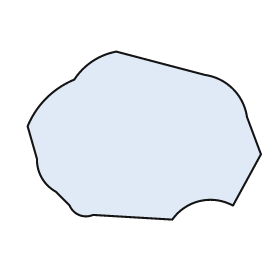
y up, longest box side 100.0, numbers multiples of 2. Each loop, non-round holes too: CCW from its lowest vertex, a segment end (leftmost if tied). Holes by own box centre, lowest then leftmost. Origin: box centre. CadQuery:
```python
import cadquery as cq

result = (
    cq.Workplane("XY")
    .moveTo(12.0, -36.0)
    .threePointArc((24.0, -28.0), (38.0, -30.0))
    .lineTo(50.0, -8.0)
    .lineTo(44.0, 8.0)
    .threePointArc((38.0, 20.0), (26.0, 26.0))
    .lineTo(-12.0, 36.0)
    .threePointArc((-22.0, 32.0), (-30.0, 24.0))
    .threePointArc((-42.0, 16.0), (-50.0, 4.0))
    .lineTo(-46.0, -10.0)
    .threePointArc((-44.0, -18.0), (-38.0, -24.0))
    .lineTo(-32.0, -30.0)
    .threePointArc((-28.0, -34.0), (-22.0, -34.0))
    .close()
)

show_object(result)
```